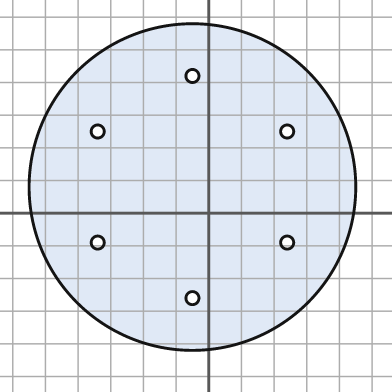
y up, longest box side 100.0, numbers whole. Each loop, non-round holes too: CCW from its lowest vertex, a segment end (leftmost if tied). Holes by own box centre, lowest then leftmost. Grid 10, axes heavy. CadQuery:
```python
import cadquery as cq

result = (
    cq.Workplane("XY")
    .moveTo(-5.0, 8.0)
    .circle(50.0)
    .moveTo(-5.0, -26.0)
    .circle(2.0)
    .moveTo(-34.0, -9.0)
    .circle(2.0)
    .moveTo(24.0, -9.0)
    .circle(2.0)
    .moveTo(-34.0, 25.0)
    .circle(2.0)
    .moveTo(24.0, 25.0)
    .circle(2.0)
    .moveTo(-5.0, 42.0)
    .circle(2.0)
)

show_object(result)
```